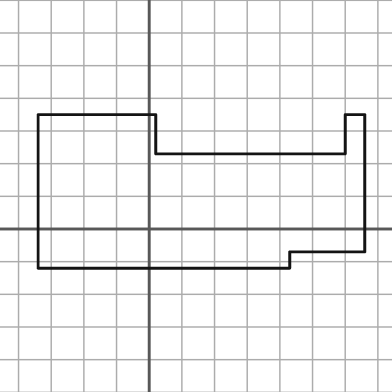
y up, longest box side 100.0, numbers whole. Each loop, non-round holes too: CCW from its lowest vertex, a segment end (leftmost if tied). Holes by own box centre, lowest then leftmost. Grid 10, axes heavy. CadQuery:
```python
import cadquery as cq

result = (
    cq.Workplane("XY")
    .moveTo(-34.0, -12.0)
    .lineTo(43.0, -12.0)
    .lineTo(43.0, -7.0)
    .lineTo(66.0, -7.0)
    .lineTo(66.0, 35.0)
    .lineTo(60.0, 35.0)
    .lineTo(60.0, 23.0)
    .lineTo(2.0, 23.0)
    .lineTo(2.0, 35.0)
    .lineTo(-34.0, 35.0)
    .close()
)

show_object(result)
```